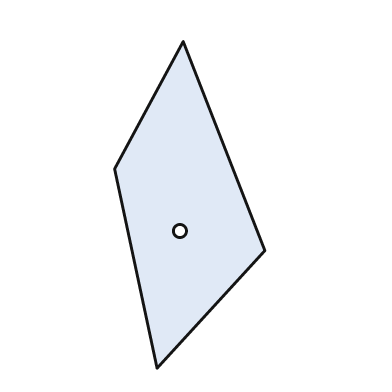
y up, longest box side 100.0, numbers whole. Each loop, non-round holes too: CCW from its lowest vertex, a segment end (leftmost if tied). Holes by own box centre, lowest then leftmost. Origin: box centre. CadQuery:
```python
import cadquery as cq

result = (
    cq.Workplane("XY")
    .moveTo(-10.0, -50.0)
    .lineTo(23.0, -14.0)
    .lineTo(-2.0, 50.0)
    .lineTo(-23.0, 11.0)
    .close()
    .moveTo(-3.0, -8.0)
    .circle(2.0)
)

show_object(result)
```